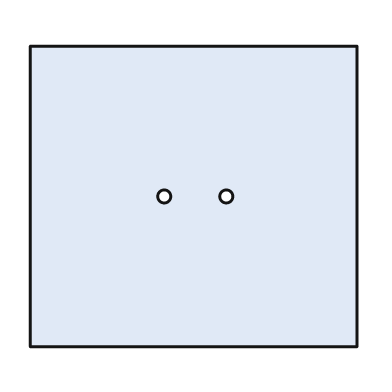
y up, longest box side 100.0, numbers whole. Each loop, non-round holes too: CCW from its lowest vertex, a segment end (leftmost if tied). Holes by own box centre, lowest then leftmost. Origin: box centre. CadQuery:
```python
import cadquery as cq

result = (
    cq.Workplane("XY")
    .moveTo(-50.0, -46.0)
    .lineTo(50.0, -46.0)
    .lineTo(50.0, 46.0)
    .lineTo(-50.0, 46.0)
    .close()
    .moveTo(-9.0, 0.0)
    .circle(2.0)
    .moveTo(10.0, 0.0)
    .circle(2.0)
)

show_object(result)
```